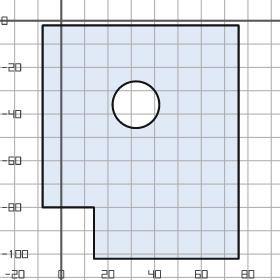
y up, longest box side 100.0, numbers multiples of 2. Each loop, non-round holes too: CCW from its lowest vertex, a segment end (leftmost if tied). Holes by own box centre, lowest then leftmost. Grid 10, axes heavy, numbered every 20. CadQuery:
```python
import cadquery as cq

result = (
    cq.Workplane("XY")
    .moveTo(14.0, -102.0)
    .lineTo(76.0, -102.0)
    .lineTo(76.0, -2.0)
    .lineTo(-8.0, -2.0)
    .lineTo(-8.0, -80.0)
    .lineTo(14.0, -80.0)
    .close()
    .moveTo(32.0, -36.0)
    .circle(10.0)
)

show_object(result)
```